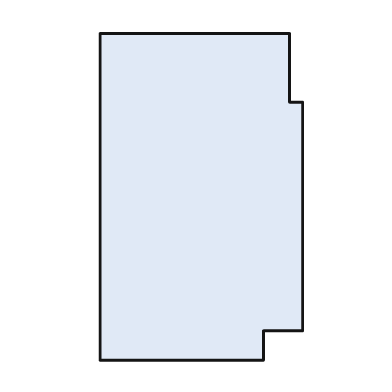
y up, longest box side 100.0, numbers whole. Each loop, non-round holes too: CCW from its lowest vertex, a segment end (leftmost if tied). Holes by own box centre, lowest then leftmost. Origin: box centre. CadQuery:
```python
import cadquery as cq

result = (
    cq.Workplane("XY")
    .moveTo(-31.0, -50.0)
    .lineTo(19.0, -50.0)
    .lineTo(19.0, -41.0)
    .lineTo(31.0, -41.0)
    .lineTo(31.0, 29.0)
    .lineTo(27.0, 29.0)
    .lineTo(27.0, 50.0)
    .lineTo(-31.0, 50.0)
    .close()
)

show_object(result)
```